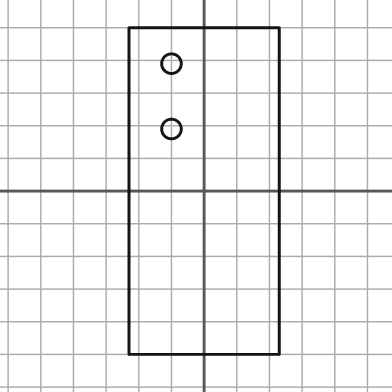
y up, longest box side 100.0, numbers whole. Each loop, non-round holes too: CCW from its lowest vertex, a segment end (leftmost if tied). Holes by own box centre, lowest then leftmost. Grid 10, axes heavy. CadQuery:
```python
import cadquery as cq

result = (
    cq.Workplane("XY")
    .moveTo(-23.0, -50.0)
    .lineTo(23.0, -50.0)
    .lineTo(23.0, 50.0)
    .lineTo(-23.0, 50.0)
    .close()
    .moveTo(-10.0, 19.0)
    .circle(3.0)
    .moveTo(-10.0, 39.0)
    .circle(3.0)
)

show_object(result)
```